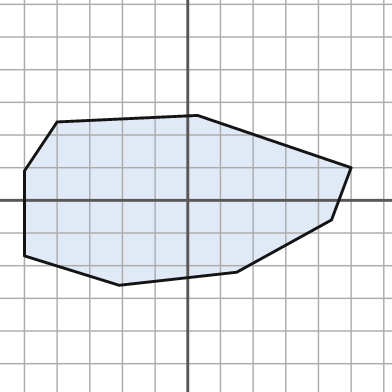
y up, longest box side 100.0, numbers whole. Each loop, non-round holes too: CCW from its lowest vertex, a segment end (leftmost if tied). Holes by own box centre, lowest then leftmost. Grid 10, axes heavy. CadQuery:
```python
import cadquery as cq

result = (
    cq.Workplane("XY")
    .moveTo(-21.0, -26.0)
    .lineTo(15.0, -22.0)
    .lineTo(44.0, -6.0)
    .lineTo(50.0, 10.0)
    .lineTo(3.0, 26.0)
    .lineTo(-40.0, 24.0)
    .lineTo(-50.0, 9.0)
    .lineTo(-50.0, -17.0)
    .close()
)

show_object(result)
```